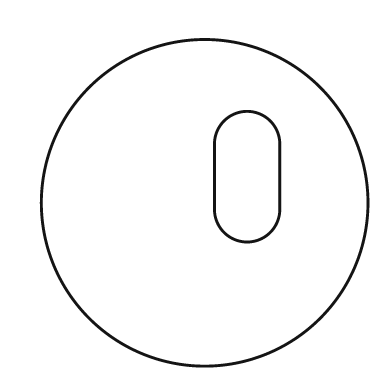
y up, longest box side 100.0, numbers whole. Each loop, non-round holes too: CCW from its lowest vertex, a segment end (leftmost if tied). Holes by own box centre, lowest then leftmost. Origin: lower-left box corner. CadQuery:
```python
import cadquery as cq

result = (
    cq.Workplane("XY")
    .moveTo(50.0, 50.0)
    .circle(50.0)
    .moveTo(53.0, 48.0)
    .threePointArc((63.0, 38.0), (73.0, 48.0))
    .lineTo(73.0, 68.0)
    .threePointArc((63.0, 78.0), (53.0, 68.0))
    .close()
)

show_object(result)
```